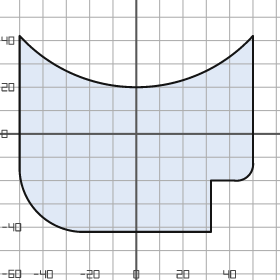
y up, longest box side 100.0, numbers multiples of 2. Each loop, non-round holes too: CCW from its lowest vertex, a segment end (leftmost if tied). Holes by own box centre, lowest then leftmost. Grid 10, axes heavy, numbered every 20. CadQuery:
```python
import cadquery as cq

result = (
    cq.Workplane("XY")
    .moveTo(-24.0, -42.0)
    .lineTo(32.0, -42.0)
    .lineTo(32.0, -20.0)
    .lineTo(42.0, -20.0)
    .threePointArc((48.0, -18.0), (50.0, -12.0))
    .lineTo(50.0, 42.0)
    .threePointArc((0.0, 20.0), (-50.0, 42.0))
    .lineTo(-50.0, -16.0)
    .threePointArc((-42.0, -34.0), (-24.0, -42.0))
    .close()
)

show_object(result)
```